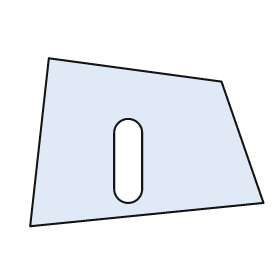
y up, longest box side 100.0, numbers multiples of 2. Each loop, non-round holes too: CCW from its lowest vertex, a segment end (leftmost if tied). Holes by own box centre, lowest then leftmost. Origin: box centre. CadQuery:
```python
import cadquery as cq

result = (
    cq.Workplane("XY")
    .moveTo(-50.0, -36.0)
    .lineTo(50.0, -26.0)
    .lineTo(32.0, 26.0)
    .lineTo(-42.0, 36.0)
    .close()
    .moveTo(-14.0, -20.0)
    .threePointArc((-8.0, -26.0), (-2.0, -20.0))
    .lineTo(-2.0, 4.0)
    .threePointArc((-8.0, 10.0), (-14.0, 4.0))
    .close()
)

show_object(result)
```